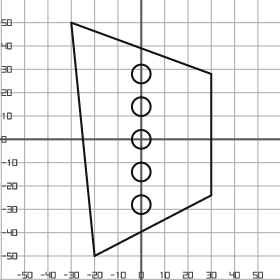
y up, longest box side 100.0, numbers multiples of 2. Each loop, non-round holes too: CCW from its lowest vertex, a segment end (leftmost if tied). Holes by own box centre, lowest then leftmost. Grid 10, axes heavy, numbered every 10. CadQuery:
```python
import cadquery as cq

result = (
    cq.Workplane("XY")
    .moveTo(-20.0, -50.0)
    .lineTo(30.0, -24.0)
    .lineTo(30.0, 28.0)
    .lineTo(-30.0, 50.0)
    .close()
    .moveTo(0.0, -28.0)
    .circle(4.0)
    .moveTo(0.0, -14.0)
    .circle(4.0)
    .moveTo(0.0, 0.0)
    .circle(4.0)
    .moveTo(0.0, 14.0)
    .circle(4.0)
    .moveTo(0.0, 28.0)
    .circle(4.0)
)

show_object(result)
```